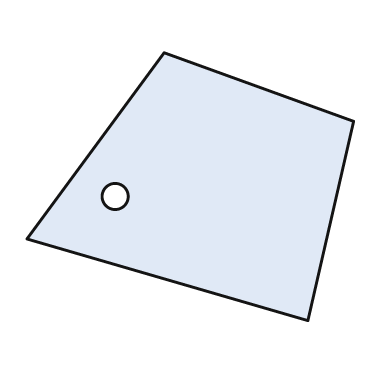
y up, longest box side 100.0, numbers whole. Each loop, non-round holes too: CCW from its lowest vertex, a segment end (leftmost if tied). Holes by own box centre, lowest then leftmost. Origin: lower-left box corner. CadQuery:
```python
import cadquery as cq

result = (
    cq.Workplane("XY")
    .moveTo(86.0, 0.0)
    .lineTo(100.0, 61.0)
    .lineTo(42.0, 82.0)
    .lineTo(0.0, 25.0)
    .close()
    .moveTo(27.0, 38.0)
    .circle(4.0)
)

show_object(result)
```